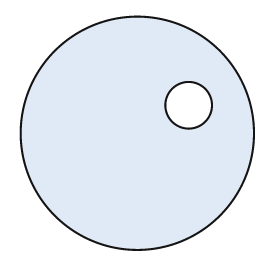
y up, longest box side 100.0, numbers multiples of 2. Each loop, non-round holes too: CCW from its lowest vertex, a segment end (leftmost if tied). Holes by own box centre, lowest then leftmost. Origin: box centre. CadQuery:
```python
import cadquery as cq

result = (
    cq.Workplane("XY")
    .moveTo(0.0, 0.0)
    .circle(50.0)
    .moveTo(22.0, 12.0)
    .circle(10.0)
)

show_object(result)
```